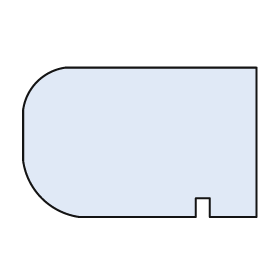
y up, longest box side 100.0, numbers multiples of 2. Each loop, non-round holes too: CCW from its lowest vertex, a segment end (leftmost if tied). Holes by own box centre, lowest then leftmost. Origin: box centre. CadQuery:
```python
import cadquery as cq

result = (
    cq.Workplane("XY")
    .moveTo(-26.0, -32.0)
    .lineTo(24.0, -32.0)
    .lineTo(24.0, -24.0)
    .lineTo(30.0, -24.0)
    .lineTo(30.0, -32.0)
    .lineTo(50.0, -32.0)
    .lineTo(50.0, 32.0)
    .lineTo(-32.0, 32.0)
    .threePointArc((-44.0, 26.0), (-50.0, 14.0))
    .lineTo(-50.0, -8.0)
    .threePointArc((-42.0, -24.0), (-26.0, -32.0))
    .close()
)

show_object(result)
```